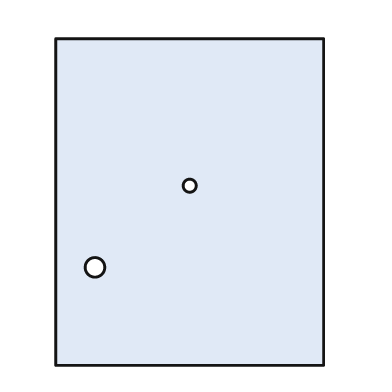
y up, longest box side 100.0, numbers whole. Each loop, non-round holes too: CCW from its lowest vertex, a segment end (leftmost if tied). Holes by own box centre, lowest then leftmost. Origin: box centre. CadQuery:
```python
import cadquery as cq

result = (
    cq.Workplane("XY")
    .moveTo(-41.0, -50.0)
    .lineTo(41.0, -50.0)
    .lineTo(41.0, 50.0)
    .lineTo(-41.0, 50.0)
    .close()
    .moveTo(-29.0, -20.0)
    .circle(3.0)
    .moveTo(0.0, 5.0)
    .circle(2.0)
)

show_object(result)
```